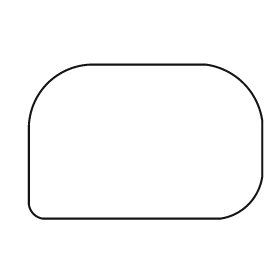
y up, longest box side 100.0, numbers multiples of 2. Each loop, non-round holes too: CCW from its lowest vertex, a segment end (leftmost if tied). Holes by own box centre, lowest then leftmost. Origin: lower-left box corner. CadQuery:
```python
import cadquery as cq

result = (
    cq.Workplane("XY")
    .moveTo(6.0, 0.0)
    .lineTo(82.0, 0.0)
    .threePointArc((94.0, 6.0), (100.0, 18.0))
    .lineTo(100.0, 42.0)
    .threePointArc((92.0, 58.0), (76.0, 66.0))
    .lineTo(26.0, 66.0)
    .threePointArc((8.0, 58.0), (0.0, 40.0))
    .lineTo(0.0, 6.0)
    .threePointArc((2.0, 2.0), (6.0, 0.0))
    .close()
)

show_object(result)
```